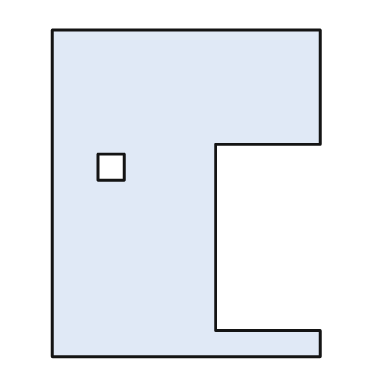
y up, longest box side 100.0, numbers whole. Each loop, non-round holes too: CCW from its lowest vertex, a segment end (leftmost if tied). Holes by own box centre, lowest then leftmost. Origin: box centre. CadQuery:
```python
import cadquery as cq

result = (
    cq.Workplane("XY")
    .moveTo(-41.0, -50.0)
    .lineTo(41.0, -50.0)
    .lineTo(41.0, -42.0)
    .lineTo(9.0, -42.0)
    .lineTo(9.0, 15.0)
    .lineTo(41.0, 15.0)
    .lineTo(41.0, 50.0)
    .lineTo(-41.0, 50.0)
    .close()
    .moveTo(-27.0, 4.0)
    .lineTo(-19.0, 4.0)
    .lineTo(-19.0, 12.0)
    .lineTo(-27.0, 12.0)
    .close()
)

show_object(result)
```